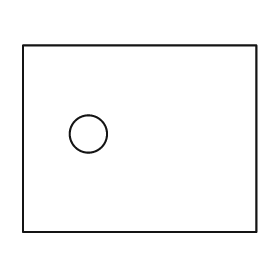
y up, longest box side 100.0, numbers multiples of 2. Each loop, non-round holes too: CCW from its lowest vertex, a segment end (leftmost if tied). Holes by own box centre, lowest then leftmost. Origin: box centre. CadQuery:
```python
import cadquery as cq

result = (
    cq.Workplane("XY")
    .moveTo(-50.0, -40.0)
    .lineTo(50.0, -40.0)
    .lineTo(50.0, 40.0)
    .lineTo(-50.0, 40.0)
    .close()
    .moveTo(-22.0, 2.0)
    .circle(8.0)
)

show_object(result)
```